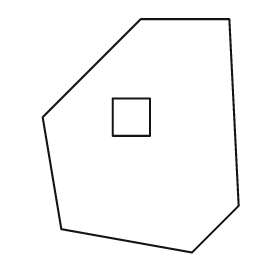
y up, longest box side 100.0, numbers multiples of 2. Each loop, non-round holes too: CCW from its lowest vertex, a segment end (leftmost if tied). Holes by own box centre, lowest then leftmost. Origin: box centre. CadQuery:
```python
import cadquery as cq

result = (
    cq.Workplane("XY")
    .moveTo(22.0, -50.0)
    .lineTo(42.0, -30.0)
    .lineTo(38.0, 50.0)
    .lineTo(0.0, 50.0)
    .lineTo(-42.0, 8.0)
    .lineTo(-34.0, -40.0)
    .close()
    .moveTo(-12.0, 0.0)
    .lineTo(4.0, 0.0)
    .lineTo(4.0, 16.0)
    .lineTo(-12.0, 16.0)
    .close()
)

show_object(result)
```